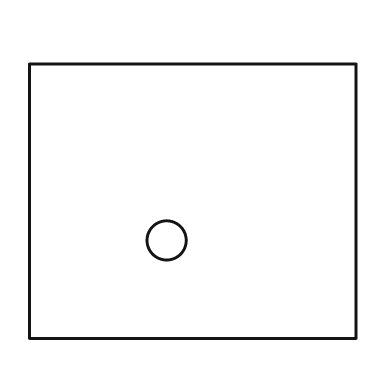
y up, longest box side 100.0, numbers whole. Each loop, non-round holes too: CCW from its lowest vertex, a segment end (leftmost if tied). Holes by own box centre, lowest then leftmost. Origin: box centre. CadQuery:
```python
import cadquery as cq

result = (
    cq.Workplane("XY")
    .moveTo(-50.0, -42.0)
    .lineTo(50.0, -42.0)
    .lineTo(50.0, 42.0)
    .lineTo(-50.0, 42.0)
    .close()
    .moveTo(-8.0, -12.0)
    .circle(6.0)
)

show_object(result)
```